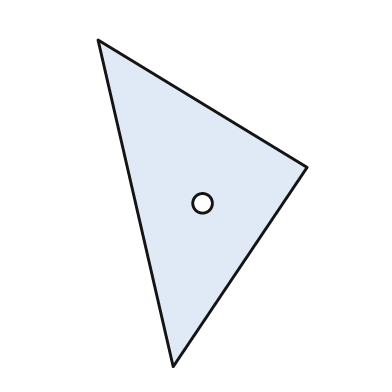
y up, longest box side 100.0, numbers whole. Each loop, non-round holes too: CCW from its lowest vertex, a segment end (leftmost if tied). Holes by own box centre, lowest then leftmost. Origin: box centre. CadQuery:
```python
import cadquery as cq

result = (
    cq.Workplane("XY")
    .moveTo(-9.0, -50.0)
    .lineTo(32.0, 11.0)
    .lineTo(-32.0, 50.0)
    .close()
    .moveTo(0.0, 0.0)
    .circle(3.0)
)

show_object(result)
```